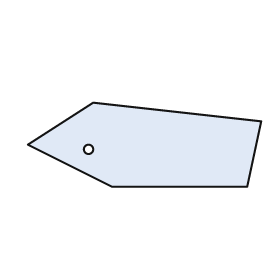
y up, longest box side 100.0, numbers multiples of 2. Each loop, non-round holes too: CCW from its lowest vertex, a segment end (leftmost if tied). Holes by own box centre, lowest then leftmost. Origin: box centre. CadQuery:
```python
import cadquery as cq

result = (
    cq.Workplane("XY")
    .moveTo(-14.0, -18.0)
    .lineTo(44.0, -18.0)
    .lineTo(50.0, 10.0)
    .lineTo(-22.0, 18.0)
    .lineTo(-50.0, 0.0)
    .close()
    .moveTo(-24.0, -2.0)
    .circle(2.0)
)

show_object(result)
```